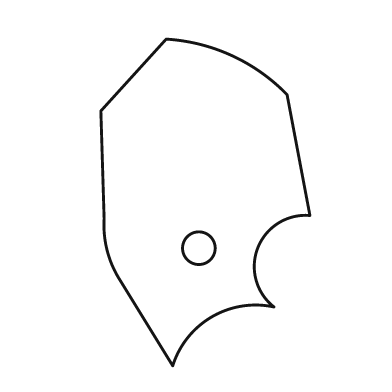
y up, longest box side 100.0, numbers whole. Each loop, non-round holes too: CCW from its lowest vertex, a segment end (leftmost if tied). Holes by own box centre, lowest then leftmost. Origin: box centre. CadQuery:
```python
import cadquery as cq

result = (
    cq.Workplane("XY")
    .moveTo(-10.0, -50.0)
    .threePointArc((2.0, -35.0), (21.0, -32.0))
    .threePointArc((16.0, -14.0), (32.0, -4.0))
    .lineTo(25.0, 33.0)
    .threePointArc((8.0, 45.0), (-12.0, 50.0))
    .lineTo(-32.0, 28.0)
    .lineTo(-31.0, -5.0)
    .threePointArc((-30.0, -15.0), (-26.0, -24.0))
    .close()
    .moveTo(-2.0, -14.0)
    .circle(5.0)
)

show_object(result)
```